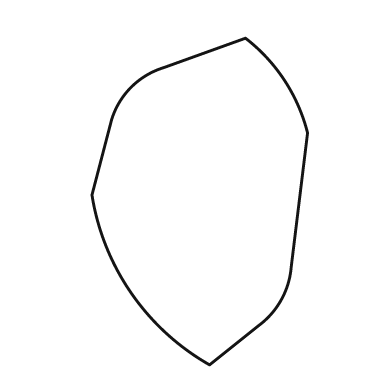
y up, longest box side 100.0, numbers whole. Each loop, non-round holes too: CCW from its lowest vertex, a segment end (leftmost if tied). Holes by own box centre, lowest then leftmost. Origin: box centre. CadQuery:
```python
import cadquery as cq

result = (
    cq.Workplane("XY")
    .moveTo(3.0, -50.0)
    .lineTo(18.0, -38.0)
    .threePointArc((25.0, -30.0), (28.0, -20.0))
    .lineTo(33.0, 21.0)
    .threePointArc((26.0, 37.0), (14.0, 50.0))
    .lineTo(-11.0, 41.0)
    .threePointArc((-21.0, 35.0), (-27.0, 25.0))
    .lineTo(-33.0, 2.0)
    .threePointArc((-21.0, -28.0), (3.0, -50.0))
    .close()
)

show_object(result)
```